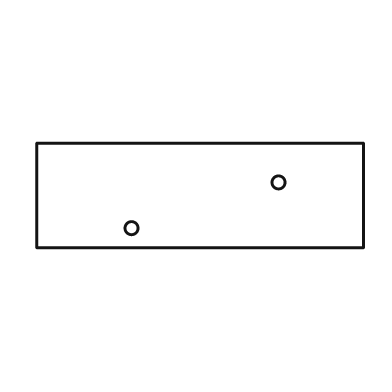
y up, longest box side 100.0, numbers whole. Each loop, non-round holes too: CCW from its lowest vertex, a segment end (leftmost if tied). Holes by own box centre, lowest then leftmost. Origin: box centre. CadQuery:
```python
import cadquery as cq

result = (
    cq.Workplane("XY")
    .moveTo(-50.0, -16.0)
    .lineTo(50.0, -16.0)
    .lineTo(50.0, 16.0)
    .lineTo(-50.0, 16.0)
    .close()
    .moveTo(-21.0, -10.0)
    .circle(2.0)
    .moveTo(24.0, 4.0)
    .circle(2.0)
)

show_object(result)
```